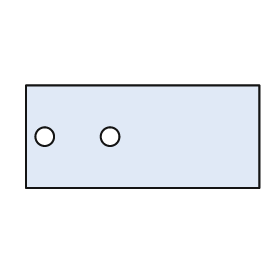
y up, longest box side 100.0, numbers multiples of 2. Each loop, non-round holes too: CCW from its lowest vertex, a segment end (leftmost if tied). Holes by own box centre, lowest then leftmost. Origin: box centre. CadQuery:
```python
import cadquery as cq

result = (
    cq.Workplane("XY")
    .moveTo(-50.0, -22.0)
    .lineTo(50.0, -22.0)
    .lineTo(50.0, 22.0)
    .lineTo(-50.0, 22.0)
    .close()
    .moveTo(-42.0, 0.0)
    .circle(4.0)
    .moveTo(-14.0, 0.0)
    .circle(4.0)
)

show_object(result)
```